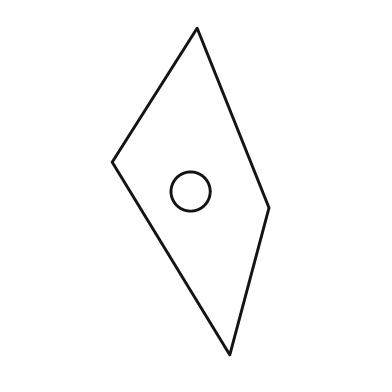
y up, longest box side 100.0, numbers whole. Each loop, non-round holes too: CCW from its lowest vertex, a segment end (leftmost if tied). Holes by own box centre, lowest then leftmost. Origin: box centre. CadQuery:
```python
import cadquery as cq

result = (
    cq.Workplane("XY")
    .moveTo(12.0, -50.0)
    .lineTo(24.0, -5.0)
    .lineTo(2.0, 50.0)
    .lineTo(-24.0, 9.0)
    .close()
    .moveTo(0.0, 0.0)
    .circle(6.0)
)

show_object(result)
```